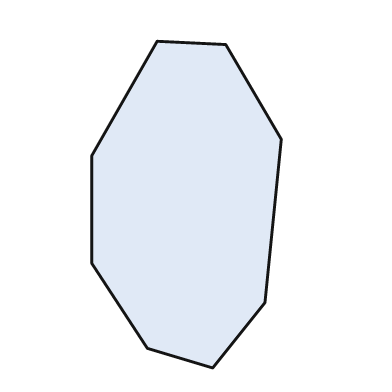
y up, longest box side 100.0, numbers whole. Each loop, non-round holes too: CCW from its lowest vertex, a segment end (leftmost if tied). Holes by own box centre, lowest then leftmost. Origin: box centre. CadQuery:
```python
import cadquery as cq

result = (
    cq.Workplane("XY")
    .moveTo(8.0, -50.0)
    .lineTo(24.0, -30.0)
    .lineTo(29.0, 20.0)
    .lineTo(12.0, 49.0)
    .lineTo(-9.0, 50.0)
    .lineTo(-29.0, 15.0)
    .lineTo(-29.0, -18.0)
    .lineTo(-12.0, -44.0)
    .close()
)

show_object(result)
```